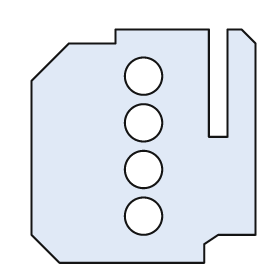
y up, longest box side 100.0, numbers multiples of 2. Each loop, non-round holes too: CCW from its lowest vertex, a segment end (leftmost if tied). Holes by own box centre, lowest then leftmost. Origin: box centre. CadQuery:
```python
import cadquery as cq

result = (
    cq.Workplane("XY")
    .moveTo(-36.0, -50.0)
    .lineTo(26.0, -50.0)
    .lineTo(26.0, -42.0)
    .lineTo(32.0, -38.0)
    .lineTo(48.0, -38.0)
    .lineTo(48.0, 44.0)
    .lineTo(42.0, 50.0)
    .lineTo(36.0, 50.0)
    .lineTo(36.0, 4.0)
    .lineTo(28.0, 4.0)
    .lineTo(28.0, 50.0)
    .lineTo(-12.0, 50.0)
    .lineTo(-12.0, 44.0)
    .lineTo(-32.0, 44.0)
    .lineTo(-48.0, 28.0)
    .lineTo(-48.0, -38.0)
    .close()
    .moveTo(0.0, -30.0)
    .circle(8.0)
    .moveTo(0.0, -10.0)
    .circle(8.0)
    .moveTo(0.0, 10.0)
    .circle(8.0)
    .moveTo(0.0, 30.0)
    .circle(8.0)
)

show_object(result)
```